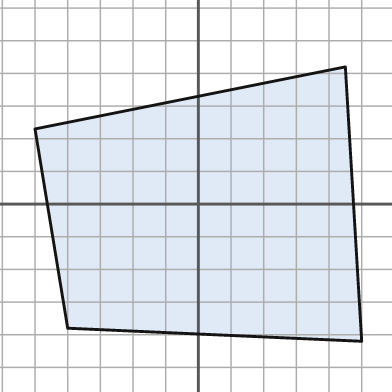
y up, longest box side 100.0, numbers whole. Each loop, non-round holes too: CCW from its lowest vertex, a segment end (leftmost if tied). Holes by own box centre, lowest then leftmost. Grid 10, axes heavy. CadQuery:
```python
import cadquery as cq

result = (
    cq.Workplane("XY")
    .moveTo(50.0, -42.0)
    .lineTo(45.0, 42.0)
    .lineTo(-50.0, 23.0)
    .lineTo(-40.0, -38.0)
    .close()
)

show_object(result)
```